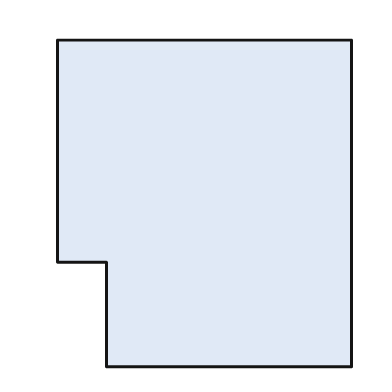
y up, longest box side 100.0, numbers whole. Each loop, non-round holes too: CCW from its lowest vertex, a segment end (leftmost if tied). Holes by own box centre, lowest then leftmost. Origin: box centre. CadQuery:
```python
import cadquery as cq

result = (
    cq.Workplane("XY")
    .moveTo(-30.0, -50.0)
    .lineTo(45.0, -50.0)
    .lineTo(45.0, 50.0)
    .lineTo(-45.0, 50.0)
    .lineTo(-45.0, -18.0)
    .lineTo(-30.0, -18.0)
    .close()
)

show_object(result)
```